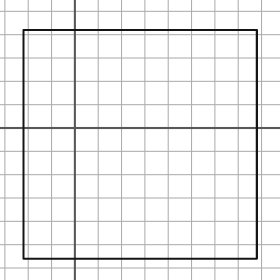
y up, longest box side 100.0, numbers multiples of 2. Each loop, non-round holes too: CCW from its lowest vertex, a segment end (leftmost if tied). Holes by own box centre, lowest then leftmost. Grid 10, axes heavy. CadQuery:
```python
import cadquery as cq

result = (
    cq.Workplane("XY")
    .moveTo(-22.0, -56.0)
    .lineTo(78.0, -56.0)
    .lineTo(78.0, 42.0)
    .lineTo(-22.0, 42.0)
    .close()
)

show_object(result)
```